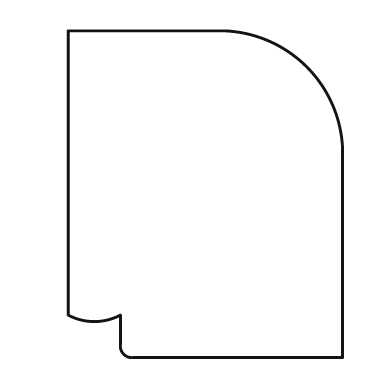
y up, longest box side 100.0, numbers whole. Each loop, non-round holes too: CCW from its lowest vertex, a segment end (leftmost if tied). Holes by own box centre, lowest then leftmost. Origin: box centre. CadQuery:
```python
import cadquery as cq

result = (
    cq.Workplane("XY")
    .moveTo(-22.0, -50.0)
    .lineTo(42.0, -50.0)
    .lineTo(42.0, 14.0)
    .threePointArc((31.0, 39.0), (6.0, 50.0))
    .lineTo(-42.0, 50.0)
    .lineTo(-42.0, -37.0)
    .threePointArc((-34.0, -39.0), (-26.0, -37.0))
    .lineTo(-26.0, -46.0)
    .threePointArc((-25.0, -49.0), (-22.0, -50.0))
    .close()
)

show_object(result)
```